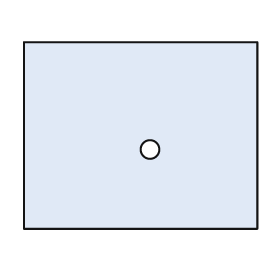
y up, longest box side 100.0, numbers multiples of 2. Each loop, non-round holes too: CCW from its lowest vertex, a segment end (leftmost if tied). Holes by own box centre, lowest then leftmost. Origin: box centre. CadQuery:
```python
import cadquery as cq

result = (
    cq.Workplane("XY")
    .moveTo(-50.0, -40.0)
    .lineTo(50.0, -40.0)
    .lineTo(50.0, 40.0)
    .lineTo(-50.0, 40.0)
    .close()
    .moveTo(4.0, -6.0)
    .circle(4.0)
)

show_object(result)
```